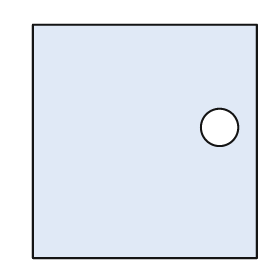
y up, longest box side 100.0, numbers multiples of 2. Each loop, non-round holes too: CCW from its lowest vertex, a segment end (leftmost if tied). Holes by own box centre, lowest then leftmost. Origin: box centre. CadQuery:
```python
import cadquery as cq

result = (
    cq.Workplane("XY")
    .moveTo(-48.0, -50.0)
    .lineTo(48.0, -50.0)
    .lineTo(48.0, 50.0)
    .lineTo(-48.0, 50.0)
    .close()
    .moveTo(32.0, 6.0)
    .circle(8.0)
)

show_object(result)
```